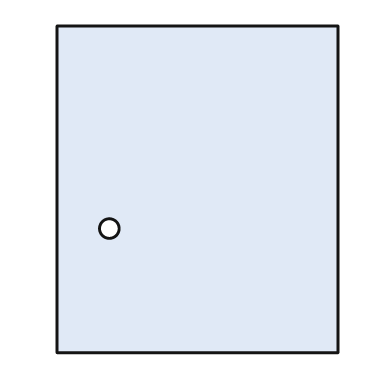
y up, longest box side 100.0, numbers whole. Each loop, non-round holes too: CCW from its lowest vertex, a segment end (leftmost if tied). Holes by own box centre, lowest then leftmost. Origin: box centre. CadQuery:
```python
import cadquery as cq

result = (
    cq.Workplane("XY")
    .moveTo(-43.0, -50.0)
    .lineTo(43.0, -50.0)
    .lineTo(43.0, 50.0)
    .lineTo(-43.0, 50.0)
    .close()
    .moveTo(-27.0, -12.0)
    .circle(3.0)
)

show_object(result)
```